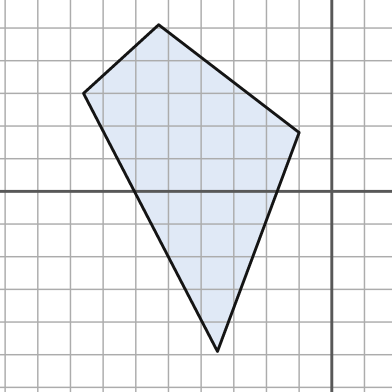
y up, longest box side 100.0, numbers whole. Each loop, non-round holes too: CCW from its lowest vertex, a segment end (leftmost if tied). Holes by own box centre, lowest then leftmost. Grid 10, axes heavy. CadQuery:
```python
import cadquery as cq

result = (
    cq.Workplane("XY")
    .moveTo(-35.0, -49.0)
    .lineTo(-10.0, 18.0)
    .lineTo(-53.0, 51.0)
    .lineTo(-76.0, 30.0)
    .close()
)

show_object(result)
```